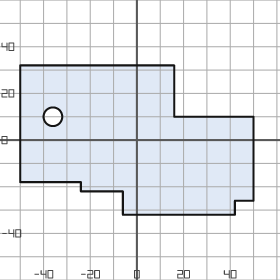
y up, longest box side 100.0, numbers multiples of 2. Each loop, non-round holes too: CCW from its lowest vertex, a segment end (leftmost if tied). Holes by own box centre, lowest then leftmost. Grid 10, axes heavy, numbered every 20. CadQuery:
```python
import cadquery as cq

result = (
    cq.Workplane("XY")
    .moveTo(-6.0, -32.0)
    .lineTo(42.0, -32.0)
    .lineTo(42.0, -26.0)
    .lineTo(50.0, -26.0)
    .lineTo(50.0, 10.0)
    .lineTo(16.0, 10.0)
    .lineTo(16.0, 32.0)
    .lineTo(-50.0, 32.0)
    .lineTo(-50.0, -18.0)
    .lineTo(-24.0, -18.0)
    .lineTo(-24.0, -22.0)
    .lineTo(-6.0, -22.0)
    .close()
    .moveTo(-36.0, 10.0)
    .circle(4.0)
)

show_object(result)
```